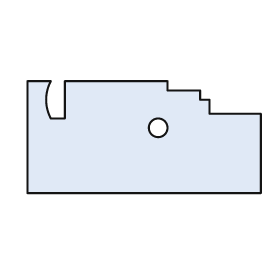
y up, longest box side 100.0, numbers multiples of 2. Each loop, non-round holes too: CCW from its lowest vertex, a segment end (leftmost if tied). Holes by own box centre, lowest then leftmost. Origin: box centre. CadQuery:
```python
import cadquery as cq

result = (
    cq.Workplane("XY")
    .moveTo(-50.0, -24.0)
    .lineTo(50.0, -24.0)
    .lineTo(50.0, 10.0)
    .lineTo(28.0, 10.0)
    .lineTo(28.0, 16.0)
    .lineTo(24.0, 16.0)
    .lineTo(24.0, 20.0)
    .lineTo(10.0, 20.0)
    .lineTo(10.0, 24.0)
    .lineTo(-34.0, 24.0)
    .lineTo(-34.0, 8.0)
    .lineTo(-40.0, 8.0)
    .threePointArc((-42.0, 16.0), (-40.0, 24.0))
    .lineTo(-50.0, 24.0)
    .close()
    .moveTo(6.0, 4.0)
    .circle(4.0)
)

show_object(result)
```